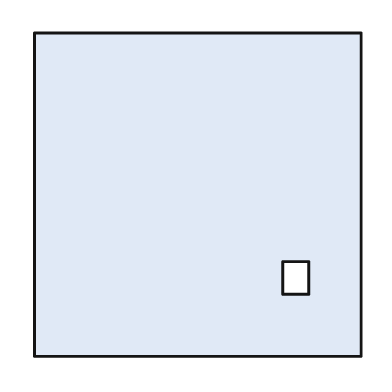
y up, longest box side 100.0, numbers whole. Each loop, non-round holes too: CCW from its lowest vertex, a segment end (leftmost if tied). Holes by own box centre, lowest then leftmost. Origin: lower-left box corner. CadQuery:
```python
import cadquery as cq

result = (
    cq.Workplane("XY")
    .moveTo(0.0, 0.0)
    .lineTo(100.0, 0.0)
    .lineTo(100.0, 99.0)
    .lineTo(0.0, 99.0)
    .close()
    .moveTo(76.0, 19.0)
    .lineTo(84.0, 19.0)
    .lineTo(84.0, 29.0)
    .lineTo(76.0, 29.0)
    .close()
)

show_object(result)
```